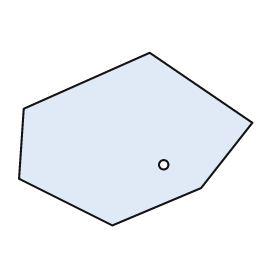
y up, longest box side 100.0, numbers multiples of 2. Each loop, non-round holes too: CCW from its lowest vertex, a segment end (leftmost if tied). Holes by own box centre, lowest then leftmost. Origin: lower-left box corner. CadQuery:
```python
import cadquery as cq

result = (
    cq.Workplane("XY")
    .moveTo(40.0, 0.0)
    .lineTo(78.0, 16.0)
    .lineTo(100.0, 44.0)
    .lineTo(56.0, 74.0)
    .lineTo(2.0, 50.0)
    .lineTo(0.0, 20.0)
    .close()
    .moveTo(62.0, 26.0)
    .circle(2.0)
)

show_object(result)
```